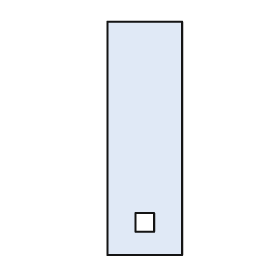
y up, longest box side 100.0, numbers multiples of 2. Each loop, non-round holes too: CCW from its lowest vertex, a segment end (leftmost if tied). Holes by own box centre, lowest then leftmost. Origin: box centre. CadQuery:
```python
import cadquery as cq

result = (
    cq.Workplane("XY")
    .moveTo(-16.0, -50.0)
    .lineTo(16.0, -50.0)
    .lineTo(16.0, 50.0)
    .lineTo(-16.0, 50.0)
    .close()
    .moveTo(-4.0, -40.0)
    .lineTo(4.0, -40.0)
    .lineTo(4.0, -32.0)
    .lineTo(-4.0, -32.0)
    .close()
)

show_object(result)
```